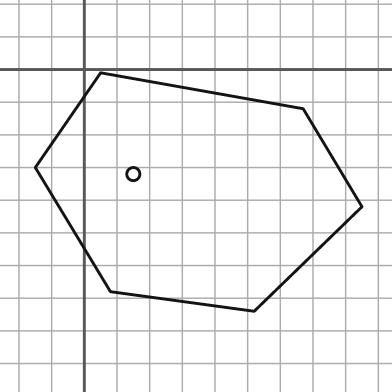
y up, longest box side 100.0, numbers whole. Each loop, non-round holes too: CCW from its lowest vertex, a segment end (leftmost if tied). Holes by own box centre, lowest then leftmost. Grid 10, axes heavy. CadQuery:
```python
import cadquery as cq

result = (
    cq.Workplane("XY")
    .moveTo(52.0, -74.0)
    .lineTo(85.0, -42.0)
    .lineTo(67.0, -12.0)
    .lineTo(5.0, -1.0)
    .lineTo(-15.0, -30.0)
    .lineTo(8.0, -68.0)
    .close()
    .moveTo(15.0, -32.0)
    .circle(2.0)
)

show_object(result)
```